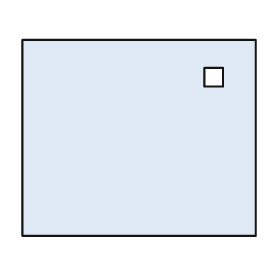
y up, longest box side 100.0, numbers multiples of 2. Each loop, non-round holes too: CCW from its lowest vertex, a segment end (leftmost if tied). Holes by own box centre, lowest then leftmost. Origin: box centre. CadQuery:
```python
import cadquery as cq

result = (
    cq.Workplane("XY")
    .moveTo(-50.0, -42.0)
    .lineTo(50.0, -42.0)
    .lineTo(50.0, 42.0)
    .lineTo(-50.0, 42.0)
    .close()
    .moveTo(28.0, 22.0)
    .lineTo(36.0, 22.0)
    .lineTo(36.0, 30.0)
    .lineTo(28.0, 30.0)
    .close()
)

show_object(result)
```